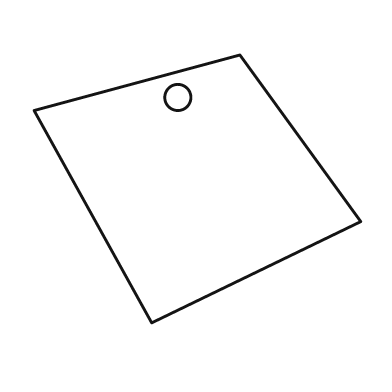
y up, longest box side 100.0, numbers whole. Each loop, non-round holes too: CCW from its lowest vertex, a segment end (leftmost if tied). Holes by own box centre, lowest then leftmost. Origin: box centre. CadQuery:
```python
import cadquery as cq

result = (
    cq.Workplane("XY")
    .moveTo(-14.0, -41.0)
    .lineTo(50.0, -10.0)
    .lineTo(13.0, 41.0)
    .lineTo(-50.0, 24.0)
    .close()
    .moveTo(-6.0, 28.0)
    .circle(4.0)
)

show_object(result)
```